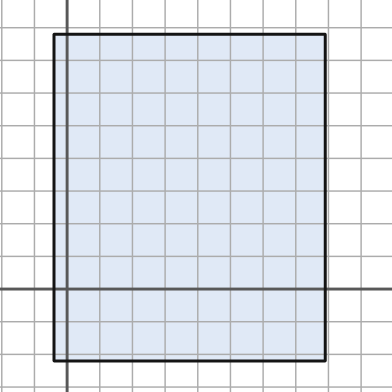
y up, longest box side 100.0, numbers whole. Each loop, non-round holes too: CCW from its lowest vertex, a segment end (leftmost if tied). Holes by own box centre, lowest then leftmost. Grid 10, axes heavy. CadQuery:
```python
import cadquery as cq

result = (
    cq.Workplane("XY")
    .moveTo(-4.0, -22.0)
    .lineTo(79.0, -22.0)
    .lineTo(79.0, 78.0)
    .lineTo(-4.0, 78.0)
    .close()
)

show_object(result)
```